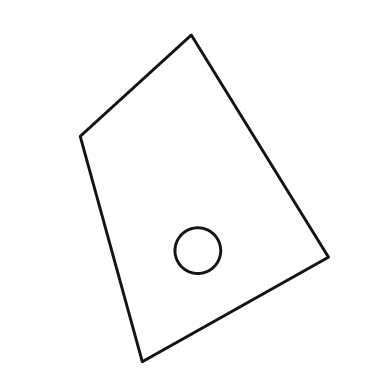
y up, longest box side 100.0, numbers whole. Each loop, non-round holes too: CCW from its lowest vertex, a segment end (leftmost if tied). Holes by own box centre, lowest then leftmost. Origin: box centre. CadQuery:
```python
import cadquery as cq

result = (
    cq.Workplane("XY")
    .moveTo(-19.0, -50.0)
    .lineTo(38.0, -18.0)
    .lineTo(-4.0, 50.0)
    .lineTo(-38.0, 19.0)
    .close()
    .moveTo(-2.0, -16.0)
    .circle(7.0)
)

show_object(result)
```